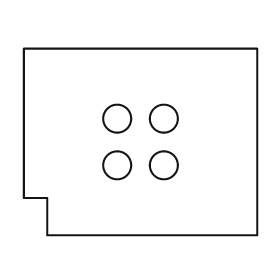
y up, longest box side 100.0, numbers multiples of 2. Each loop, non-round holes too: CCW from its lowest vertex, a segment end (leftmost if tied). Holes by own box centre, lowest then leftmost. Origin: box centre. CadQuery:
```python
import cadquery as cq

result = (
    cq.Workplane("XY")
    .moveTo(-40.0, -40.0)
    .lineTo(50.0, -40.0)
    .lineTo(50.0, 40.0)
    .lineTo(-50.0, 40.0)
    .lineTo(-50.0, -24.0)
    .lineTo(-40.0, -24.0)
    .close()
    .moveTo(-10.0, -10.0)
    .circle(6.0)
    .moveTo(10.0, -10.0)
    .circle(6.0)
    .moveTo(-10.0, 10.0)
    .circle(6.0)
    .moveTo(10.0, 10.0)
    .circle(6.0)
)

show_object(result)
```